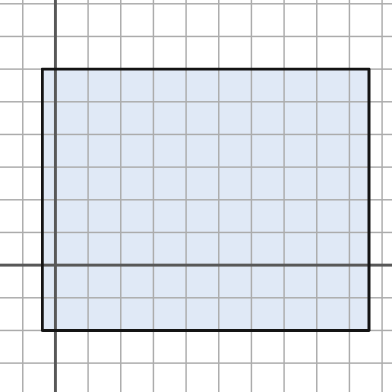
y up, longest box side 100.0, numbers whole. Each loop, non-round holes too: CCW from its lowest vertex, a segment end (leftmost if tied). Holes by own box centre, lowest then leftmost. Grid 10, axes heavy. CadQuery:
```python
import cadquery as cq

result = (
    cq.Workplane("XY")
    .moveTo(-4.0, -20.0)
    .lineTo(96.0, -20.0)
    .lineTo(96.0, 60.0)
    .lineTo(-4.0, 60.0)
    .close()
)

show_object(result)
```